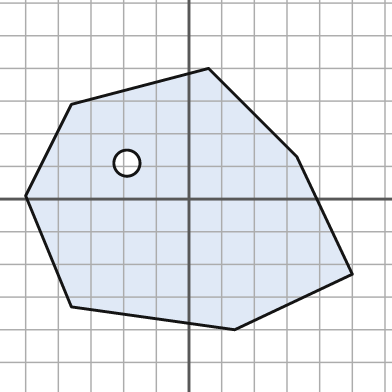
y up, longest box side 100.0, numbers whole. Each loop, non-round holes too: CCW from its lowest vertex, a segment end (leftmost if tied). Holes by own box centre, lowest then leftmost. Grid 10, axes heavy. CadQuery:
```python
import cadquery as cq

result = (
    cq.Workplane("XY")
    .moveTo(14.0, -40.0)
    .lineTo(50.0, -23.0)
    .lineTo(33.0, 13.0)
    .lineTo(6.0, 40.0)
    .lineTo(-36.0, 29.0)
    .lineTo(-50.0, 1.0)
    .lineTo(-36.0, -33.0)
    .close()
    .moveTo(-19.0, 11.0)
    .circle(4.0)
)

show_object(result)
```